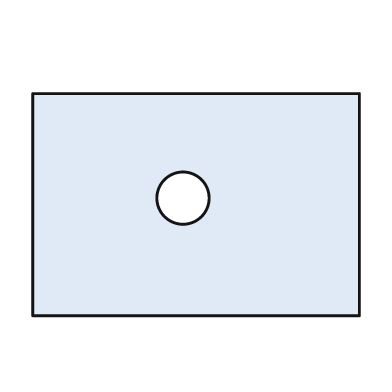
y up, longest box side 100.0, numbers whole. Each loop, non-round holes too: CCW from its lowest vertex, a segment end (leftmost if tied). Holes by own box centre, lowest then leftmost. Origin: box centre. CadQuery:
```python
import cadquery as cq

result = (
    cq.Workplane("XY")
    .moveTo(-50.0, -34.0)
    .lineTo(50.0, -34.0)
    .lineTo(50.0, 34.0)
    .lineTo(-50.0, 34.0)
    .close()
    .moveTo(-4.0, 2.0)
    .circle(8.0)
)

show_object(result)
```